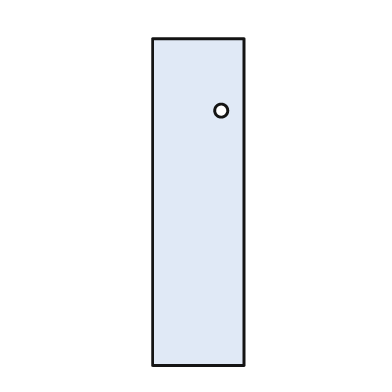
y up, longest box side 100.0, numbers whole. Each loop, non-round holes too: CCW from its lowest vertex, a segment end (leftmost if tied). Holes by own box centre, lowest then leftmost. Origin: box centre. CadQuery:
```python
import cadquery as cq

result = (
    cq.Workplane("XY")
    .moveTo(-14.0, -50.0)
    .lineTo(14.0, -50.0)
    .lineTo(14.0, 50.0)
    .lineTo(-14.0, 50.0)
    .close()
    .moveTo(7.0, 28.0)
    .circle(2.0)
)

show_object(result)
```